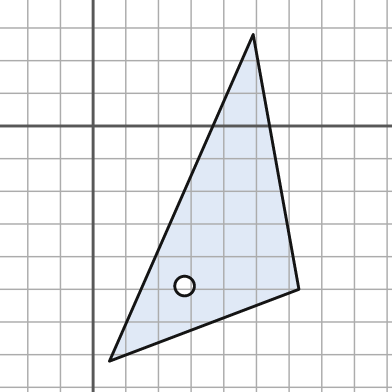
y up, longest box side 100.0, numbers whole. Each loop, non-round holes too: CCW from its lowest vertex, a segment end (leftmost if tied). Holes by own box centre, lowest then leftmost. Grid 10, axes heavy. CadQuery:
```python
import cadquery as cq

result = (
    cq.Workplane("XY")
    .moveTo(5.0, -72.0)
    .lineTo(63.0, -50.0)
    .lineTo(49.0, 28.0)
    .close()
    .moveTo(28.0, -49.0)
    .circle(3.0)
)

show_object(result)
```